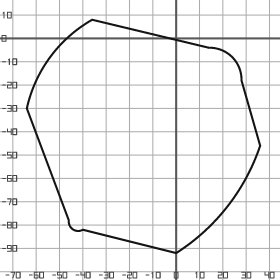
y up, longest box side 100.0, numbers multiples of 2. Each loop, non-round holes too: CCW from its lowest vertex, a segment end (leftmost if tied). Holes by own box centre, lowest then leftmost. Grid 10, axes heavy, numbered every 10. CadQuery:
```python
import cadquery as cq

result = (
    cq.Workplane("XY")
    .moveTo(0.0, -92.0)
    .threePointArc((22.0, -72.0), (36.0, -46.0))
    .lineTo(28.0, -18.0)
    .threePointArc((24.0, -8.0), (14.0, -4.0))
    .lineTo(-36.0, 8.0)
    .threePointArc((-54.0, -8.0), (-64.0, -30.0))
    .lineTo(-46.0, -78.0)
    .threePointArc((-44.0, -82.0), (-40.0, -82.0))
    .close()
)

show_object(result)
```